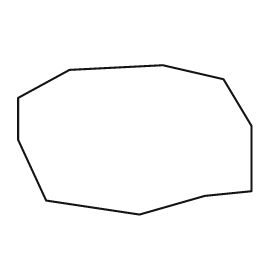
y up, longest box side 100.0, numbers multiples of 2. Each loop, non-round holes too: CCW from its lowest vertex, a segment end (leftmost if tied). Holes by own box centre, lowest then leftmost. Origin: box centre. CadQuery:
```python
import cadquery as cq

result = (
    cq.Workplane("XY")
    .moveTo(2.0, -32.0)
    .lineTo(30.0, -24.0)
    .lineTo(50.0, -22.0)
    .lineTo(50.0, 6.0)
    .lineTo(38.0, 26.0)
    .lineTo(12.0, 32.0)
    .lineTo(-28.0, 30.0)
    .lineTo(-50.0, 18.0)
    .lineTo(-50.0, 0.0)
    .lineTo(-38.0, -26.0)
    .close()
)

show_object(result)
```